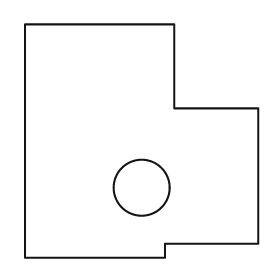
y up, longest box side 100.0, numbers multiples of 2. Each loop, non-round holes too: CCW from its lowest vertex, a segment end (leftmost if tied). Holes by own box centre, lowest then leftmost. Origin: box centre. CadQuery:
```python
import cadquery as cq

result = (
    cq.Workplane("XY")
    .moveTo(-50.0, -50.0)
    .lineTo(10.0, -50.0)
    .lineTo(10.0, -44.0)
    .lineTo(50.0, -44.0)
    .lineTo(50.0, 14.0)
    .lineTo(14.0, 14.0)
    .lineTo(14.0, 50.0)
    .lineTo(-50.0, 50.0)
    .close()
    .moveTo(0.0, -20.0)
    .circle(12.0)
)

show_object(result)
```